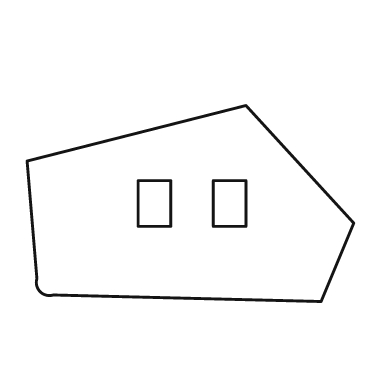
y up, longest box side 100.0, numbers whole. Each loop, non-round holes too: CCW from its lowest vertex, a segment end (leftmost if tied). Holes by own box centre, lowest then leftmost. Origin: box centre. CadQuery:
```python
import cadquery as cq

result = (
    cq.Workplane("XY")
    .moveTo(40.0, -30.0)
    .lineTo(50.0, -6.0)
    .lineTo(17.0, 30.0)
    .lineTo(-50.0, 13.0)
    .lineTo(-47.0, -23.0)
    .threePointArc((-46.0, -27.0), (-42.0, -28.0))
    .close()
    .moveTo(-16.0, -7.0)
    .lineTo(-6.0, -7.0)
    .lineTo(-6.0, 7.0)
    .lineTo(-16.0, 7.0)
    .close()
    .moveTo(7.0, -7.0)
    .lineTo(17.0, -7.0)
    .lineTo(17.0, 7.0)
    .lineTo(7.0, 7.0)
    .close()
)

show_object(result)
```